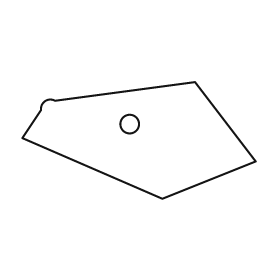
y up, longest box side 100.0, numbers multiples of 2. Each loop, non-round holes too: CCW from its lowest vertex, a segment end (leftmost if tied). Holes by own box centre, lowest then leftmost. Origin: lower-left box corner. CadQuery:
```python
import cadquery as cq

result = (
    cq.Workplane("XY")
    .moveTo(60.0, 0.0)
    .lineTo(100.0, 16.0)
    .lineTo(74.0, 50.0)
    .lineTo(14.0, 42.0)
    .threePointArc((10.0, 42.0), (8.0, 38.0))
    .lineTo(0.0, 26.0)
    .close()
    .moveTo(46.0, 32.0)
    .circle(4.0)
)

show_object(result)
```